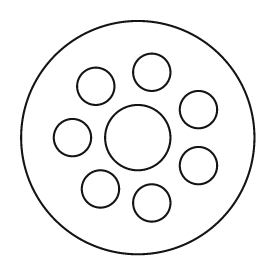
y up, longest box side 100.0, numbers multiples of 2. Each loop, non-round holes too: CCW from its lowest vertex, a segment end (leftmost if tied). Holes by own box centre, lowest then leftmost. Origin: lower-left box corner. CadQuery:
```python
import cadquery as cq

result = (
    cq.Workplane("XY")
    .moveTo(50.0, 50.0)
    .circle(50.0)
    .moveTo(56.0, 22.0)
    .circle(8.0)
    .moveTo(34.0, 28.0)
    .circle(8.0)
    .moveTo(76.0, 38.0)
    .circle(8.0)
    .moveTo(22.0, 50.0)
    .circle(8.0)
    .moveTo(50.0, 50.0)
    .circle(14.0)
    .moveTo(76.0, 62.0)
    .circle(8.0)
    .moveTo(32.0, 72.0)
    .circle(8.0)
    .moveTo(56.0, 78.0)
    .circle(8.0)
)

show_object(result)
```